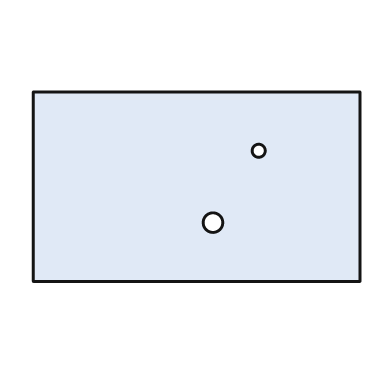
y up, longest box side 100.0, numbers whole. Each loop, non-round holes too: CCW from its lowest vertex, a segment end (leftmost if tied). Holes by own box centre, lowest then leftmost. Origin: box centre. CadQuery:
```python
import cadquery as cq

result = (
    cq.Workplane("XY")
    .moveTo(-50.0, -29.0)
    .lineTo(50.0, -29.0)
    .lineTo(50.0, 29.0)
    .lineTo(-50.0, 29.0)
    .close()
    .moveTo(5.0, -11.0)
    .circle(3.0)
    .moveTo(19.0, 11.0)
    .circle(2.0)
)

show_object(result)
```